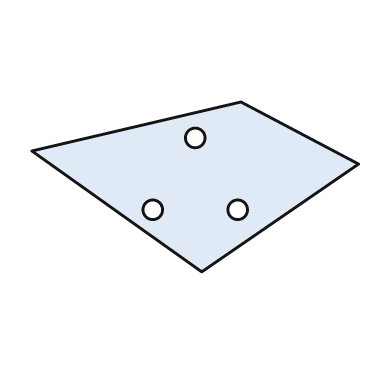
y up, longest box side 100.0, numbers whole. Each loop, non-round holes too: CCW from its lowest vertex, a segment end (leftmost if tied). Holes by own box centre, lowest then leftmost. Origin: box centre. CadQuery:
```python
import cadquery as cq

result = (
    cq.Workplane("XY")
    .moveTo(2.0, -26.0)
    .lineTo(50.0, 7.0)
    .lineTo(14.0, 26.0)
    .lineTo(-50.0, 11.0)
    .close()
    .moveTo(-13.0, -7.0)
    .circle(3.0)
    .moveTo(13.0, -7.0)
    .circle(3.0)
    .moveTo(0.0, 15.0)
    .circle(3.0)
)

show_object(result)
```